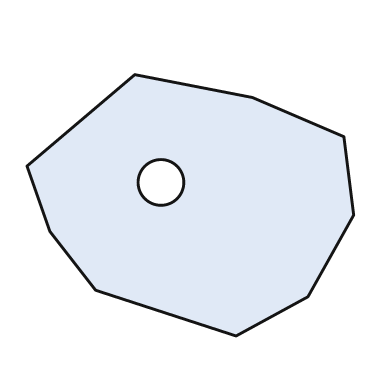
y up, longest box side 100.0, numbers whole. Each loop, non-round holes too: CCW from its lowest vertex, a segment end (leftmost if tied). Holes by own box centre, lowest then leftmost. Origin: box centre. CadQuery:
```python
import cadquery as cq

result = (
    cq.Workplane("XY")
    .moveTo(14.0, -40.0)
    .lineTo(36.0, -28.0)
    .lineTo(50.0, -3.0)
    .lineTo(47.0, 21.0)
    .lineTo(19.0, 33.0)
    .lineTo(-17.0, 40.0)
    .lineTo(-50.0, 12.0)
    .lineTo(-43.0, -8.0)
    .lineTo(-29.0, -26.0)
    .close()
    .moveTo(-9.0, 7.0)
    .circle(7.0)
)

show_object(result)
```